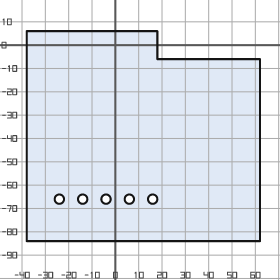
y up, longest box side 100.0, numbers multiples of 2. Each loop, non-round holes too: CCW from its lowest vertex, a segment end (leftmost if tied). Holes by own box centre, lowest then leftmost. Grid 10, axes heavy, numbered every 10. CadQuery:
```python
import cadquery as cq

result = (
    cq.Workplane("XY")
    .moveTo(-38.0, -84.0)
    .lineTo(62.0, -84.0)
    .lineTo(62.0, -6.0)
    .lineTo(18.0, -6.0)
    .lineTo(18.0, 6.0)
    .lineTo(-38.0, 6.0)
    .close()
    .moveTo(-24.0, -66.0)
    .circle(2.0)
    .moveTo(-14.0, -66.0)
    .circle(2.0)
    .moveTo(-4.0, -66.0)
    .circle(2.0)
    .moveTo(6.0, -66.0)
    .circle(2.0)
    .moveTo(16.0, -66.0)
    .circle(2.0)
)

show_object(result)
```